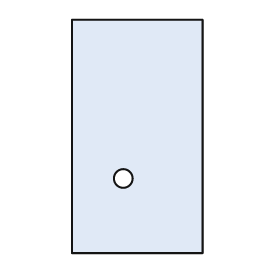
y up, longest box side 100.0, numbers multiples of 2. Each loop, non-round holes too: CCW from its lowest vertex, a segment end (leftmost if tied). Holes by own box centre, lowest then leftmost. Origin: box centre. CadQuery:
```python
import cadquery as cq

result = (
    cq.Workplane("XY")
    .moveTo(-28.0, -50.0)
    .lineTo(28.0, -50.0)
    .lineTo(28.0, 50.0)
    .lineTo(-28.0, 50.0)
    .close()
    .moveTo(-6.0, -18.0)
    .circle(4.0)
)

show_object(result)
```